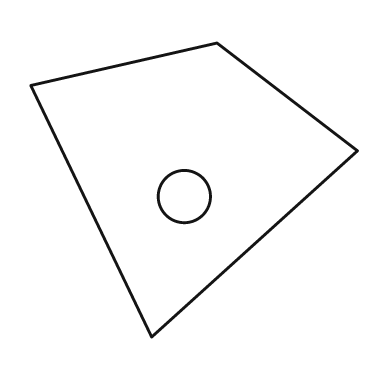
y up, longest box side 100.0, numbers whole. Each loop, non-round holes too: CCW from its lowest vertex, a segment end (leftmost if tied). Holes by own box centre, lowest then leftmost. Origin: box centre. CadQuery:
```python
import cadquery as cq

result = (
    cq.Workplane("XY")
    .moveTo(-13.0, -45.0)
    .lineTo(50.0, 12.0)
    .lineTo(7.0, 45.0)
    .lineTo(-50.0, 32.0)
    .close()
    .moveTo(-3.0, -2.0)
    .circle(8.0)
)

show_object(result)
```